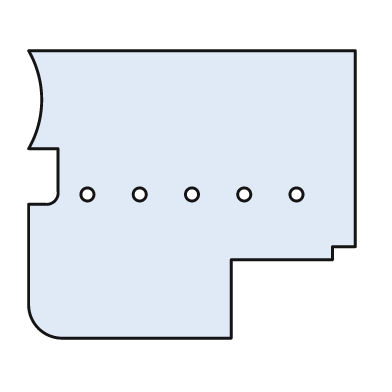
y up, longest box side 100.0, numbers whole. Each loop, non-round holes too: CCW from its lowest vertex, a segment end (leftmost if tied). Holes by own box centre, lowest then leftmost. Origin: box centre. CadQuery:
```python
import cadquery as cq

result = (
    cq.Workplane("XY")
    .moveTo(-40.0, -44.0)
    .lineTo(12.0, -44.0)
    .lineTo(12.0, -20.0)
    .lineTo(43.0, -20.0)
    .lineTo(43.0, -16.0)
    .lineTo(50.0, -16.0)
    .lineTo(50.0, 44.0)
    .lineTo(-50.0, 44.0)
    .threePointArc((-46.0, 29.0), (-50.0, 14.0))
    .lineTo(-41.0, 14.0)
    .lineTo(-41.0, 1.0)
    .threePointArc((-42.0, -2.0), (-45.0, -3.0))
    .lineTo(-50.0, -3.0)
    .lineTo(-50.0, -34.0)
    .threePointArc((-47.0, -41.0), (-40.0, -44.0))
    .close()
    .moveTo(-32.0, 0.0)
    .circle(2.0)
    .moveTo(-16.0, 0.0)
    .circle(2.0)
    .moveTo(0.0, 0.0)
    .circle(2.0)
    .moveTo(16.0, 0.0)
    .circle(2.0)
    .moveTo(32.0, 0.0)
    .circle(2.0)
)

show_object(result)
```